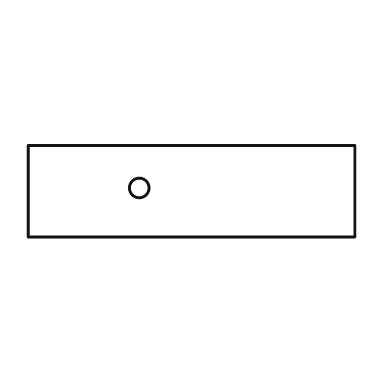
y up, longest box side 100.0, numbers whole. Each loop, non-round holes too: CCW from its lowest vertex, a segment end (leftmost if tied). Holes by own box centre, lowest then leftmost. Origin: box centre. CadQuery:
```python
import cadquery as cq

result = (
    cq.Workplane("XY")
    .moveTo(-50.0, -14.0)
    .lineTo(50.0, -14.0)
    .lineTo(50.0, 14.0)
    .lineTo(-50.0, 14.0)
    .close()
    .moveTo(-16.0, 1.0)
    .circle(3.0)
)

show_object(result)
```